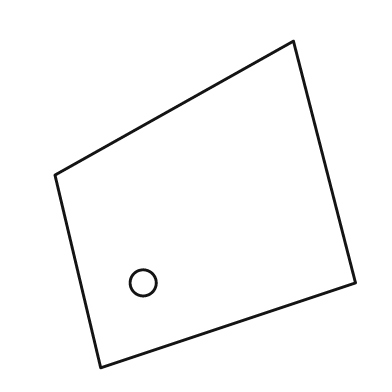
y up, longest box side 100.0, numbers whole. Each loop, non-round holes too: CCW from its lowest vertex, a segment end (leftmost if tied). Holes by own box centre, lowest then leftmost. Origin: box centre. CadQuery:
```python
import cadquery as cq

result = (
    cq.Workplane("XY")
    .moveTo(-32.0, -50.0)
    .lineTo(46.0, -24.0)
    .lineTo(27.0, 50.0)
    .lineTo(-46.0, 9.0)
    .close()
    .moveTo(-19.0, -24.0)
    .circle(4.0)
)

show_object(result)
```